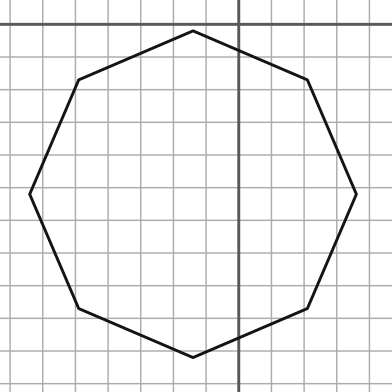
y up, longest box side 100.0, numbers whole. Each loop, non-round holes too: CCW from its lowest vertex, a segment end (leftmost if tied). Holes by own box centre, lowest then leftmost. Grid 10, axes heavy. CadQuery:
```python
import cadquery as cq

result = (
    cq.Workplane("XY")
    .moveTo(-14.0, -102.0)
    .lineTo(21.0, -87.0)
    .lineTo(36.0, -52.0)
    .lineTo(21.0, -17.0)
    .lineTo(-14.0, -2.0)
    .lineTo(-49.0, -17.0)
    .lineTo(-64.0, -52.0)
    .lineTo(-49.0, -87.0)
    .close()
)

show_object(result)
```